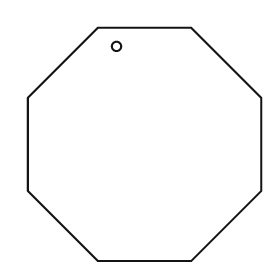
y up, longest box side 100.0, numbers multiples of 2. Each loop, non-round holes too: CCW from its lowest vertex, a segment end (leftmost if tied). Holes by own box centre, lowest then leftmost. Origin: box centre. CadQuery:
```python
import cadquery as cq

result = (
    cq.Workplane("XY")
    .moveTo(-20.0, -50.0)
    .lineTo(20.0, -50.0)
    .lineTo(50.0, -20.0)
    .lineTo(50.0, 20.0)
    .lineTo(20.0, 50.0)
    .lineTo(-20.0, 50.0)
    .lineTo(-50.0, 20.0)
    .lineTo(-50.0, -20.0)
    .close()
    .moveTo(-12.0, 42.0)
    .circle(2.0)
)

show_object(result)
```